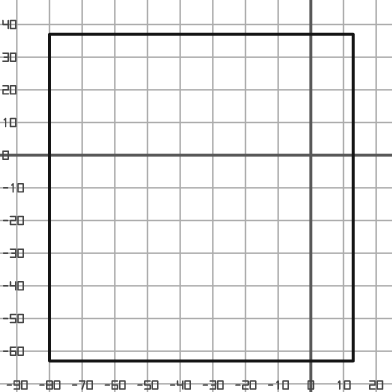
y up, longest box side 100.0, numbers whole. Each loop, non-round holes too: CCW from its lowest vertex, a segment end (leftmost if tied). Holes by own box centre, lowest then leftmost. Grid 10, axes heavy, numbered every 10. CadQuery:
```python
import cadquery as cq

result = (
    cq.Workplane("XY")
    .moveTo(-80.0, -63.0)
    .lineTo(13.0, -63.0)
    .lineTo(13.0, 37.0)
    .lineTo(-80.0, 37.0)
    .close()
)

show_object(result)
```